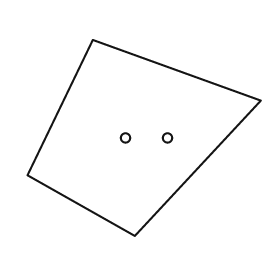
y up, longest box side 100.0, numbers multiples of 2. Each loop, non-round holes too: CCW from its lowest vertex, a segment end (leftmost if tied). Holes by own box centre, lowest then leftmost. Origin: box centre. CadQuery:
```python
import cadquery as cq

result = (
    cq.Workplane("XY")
    .moveTo(-4.0, -42.0)
    .lineTo(50.0, 16.0)
    .lineTo(-22.0, 42.0)
    .lineTo(-50.0, -16.0)
    .close()
    .moveTo(-8.0, 0.0)
    .circle(2.0)
    .moveTo(10.0, 0.0)
    .circle(2.0)
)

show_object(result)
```